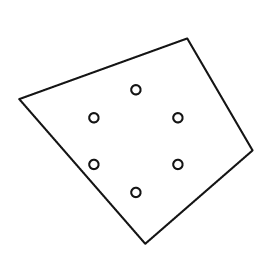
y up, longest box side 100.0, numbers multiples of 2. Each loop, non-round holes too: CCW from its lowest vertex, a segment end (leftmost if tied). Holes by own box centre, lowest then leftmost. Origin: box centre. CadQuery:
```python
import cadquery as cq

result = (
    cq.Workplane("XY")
    .moveTo(4.0, -44.0)
    .lineTo(50.0, -4.0)
    .lineTo(22.0, 44.0)
    .lineTo(-50.0, 18.0)
    .close()
    .moveTo(0.0, -22.0)
    .circle(2.0)
    .moveTo(-18.0, -10.0)
    .circle(2.0)
    .moveTo(18.0, -10.0)
    .circle(2.0)
    .moveTo(-18.0, 10.0)
    .circle(2.0)
    .moveTo(18.0, 10.0)
    .circle(2.0)
    .moveTo(0.0, 22.0)
    .circle(2.0)
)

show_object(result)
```